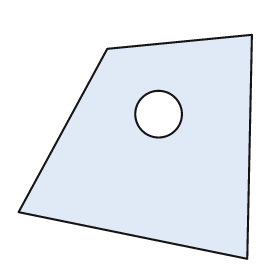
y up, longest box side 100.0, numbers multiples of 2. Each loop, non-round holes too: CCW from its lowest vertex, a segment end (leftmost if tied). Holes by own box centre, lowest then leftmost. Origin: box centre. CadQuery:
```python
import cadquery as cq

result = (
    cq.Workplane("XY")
    .moveTo(48.0, -48.0)
    .lineTo(50.0, 48.0)
    .lineTo(-12.0, 42.0)
    .lineTo(-50.0, -28.0)
    .close()
    .moveTo(10.0, 14.0)
    .circle(10.0)
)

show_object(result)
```